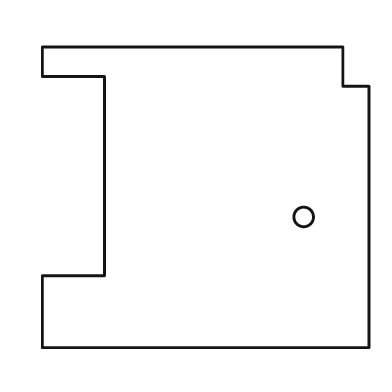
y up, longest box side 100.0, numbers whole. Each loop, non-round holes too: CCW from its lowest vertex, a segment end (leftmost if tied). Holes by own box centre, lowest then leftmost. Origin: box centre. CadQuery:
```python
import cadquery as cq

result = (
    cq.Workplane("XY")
    .moveTo(-50.0, -46.0)
    .lineTo(50.0, -46.0)
    .lineTo(50.0, 34.0)
    .lineTo(42.0, 34.0)
    .lineTo(42.0, 46.0)
    .lineTo(-50.0, 46.0)
    .lineTo(-50.0, 37.0)
    .lineTo(-31.0, 37.0)
    .lineTo(-31.0, -24.0)
    .lineTo(-50.0, -24.0)
    .close()
    .moveTo(30.0, -6.0)
    .circle(3.0)
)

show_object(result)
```